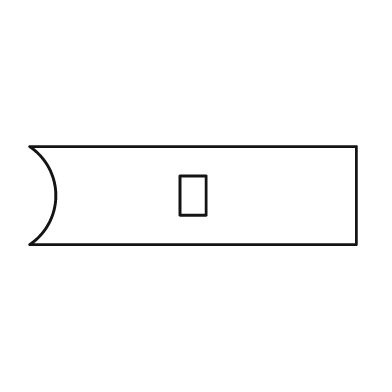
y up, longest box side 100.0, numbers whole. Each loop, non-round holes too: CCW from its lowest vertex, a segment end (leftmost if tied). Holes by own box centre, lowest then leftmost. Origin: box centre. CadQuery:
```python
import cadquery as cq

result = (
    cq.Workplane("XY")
    .moveTo(-50.0, -15.0)
    .lineTo(50.0, -15.0)
    .lineTo(50.0, 15.0)
    .lineTo(-50.0, 15.0)
    .threePointArc((-42.0, 0.0), (-50.0, -15.0))
    .close()
    .moveTo(-4.0, -6.0)
    .lineTo(4.0, -6.0)
    .lineTo(4.0, 6.0)
    .lineTo(-4.0, 6.0)
    .close()
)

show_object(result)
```